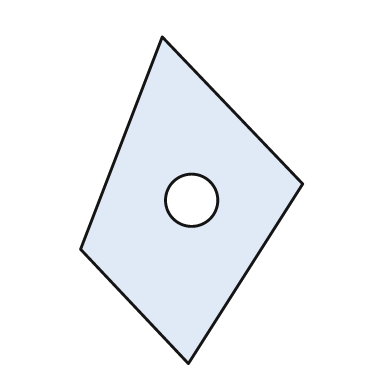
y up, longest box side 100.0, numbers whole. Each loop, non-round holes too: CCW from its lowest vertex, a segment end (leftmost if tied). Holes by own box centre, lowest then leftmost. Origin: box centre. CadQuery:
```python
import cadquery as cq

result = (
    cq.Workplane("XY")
    .moveTo(-1.0, -50.0)
    .lineTo(34.0, 5.0)
    .lineTo(-9.0, 50.0)
    .lineTo(-34.0, -15.0)
    .close()
    .moveTo(0.0, 0.0)
    .circle(8.0)
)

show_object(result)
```